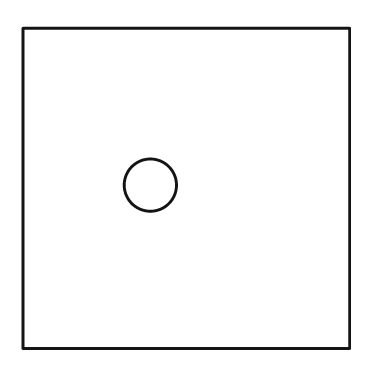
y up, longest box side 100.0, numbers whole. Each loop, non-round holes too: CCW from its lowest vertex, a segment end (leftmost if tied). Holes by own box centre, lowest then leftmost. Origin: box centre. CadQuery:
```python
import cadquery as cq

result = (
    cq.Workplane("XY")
    .moveTo(-50.0, -49.0)
    .lineTo(50.0, -49.0)
    .lineTo(50.0, 49.0)
    .lineTo(-50.0, 49.0)
    .close()
    .moveTo(-11.0, 1.0)
    .circle(8.0)
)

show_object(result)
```